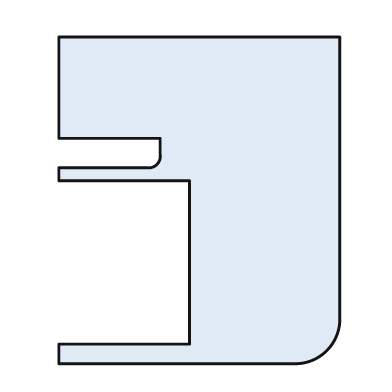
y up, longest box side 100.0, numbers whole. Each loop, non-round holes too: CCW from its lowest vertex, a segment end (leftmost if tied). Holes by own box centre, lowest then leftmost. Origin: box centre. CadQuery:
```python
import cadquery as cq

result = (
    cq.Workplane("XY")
    .moveTo(-43.0, -50.0)
    .lineTo(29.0, -50.0)
    .threePointArc((39.0, -46.0), (43.0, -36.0))
    .lineTo(43.0, 50.0)
    .lineTo(-43.0, 50.0)
    .lineTo(-43.0, 19.0)
    .lineTo(-12.0, 19.0)
    .lineTo(-12.0, 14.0)
    .threePointArc((-13.0, 11.0), (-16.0, 10.0))
    .lineTo(-43.0, 10.0)
    .lineTo(-43.0, 6.0)
    .lineTo(-3.0, 6.0)
    .lineTo(-3.0, -44.0)
    .lineTo(-43.0, -44.0)
    .close()
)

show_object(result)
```